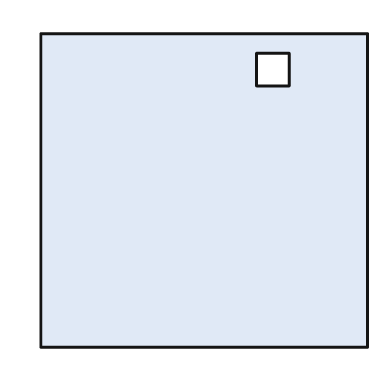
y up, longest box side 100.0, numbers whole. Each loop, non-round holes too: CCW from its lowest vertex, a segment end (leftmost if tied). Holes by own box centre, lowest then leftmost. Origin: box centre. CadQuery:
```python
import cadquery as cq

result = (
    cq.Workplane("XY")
    .moveTo(-50.0, -48.0)
    .lineTo(50.0, -48.0)
    .lineTo(50.0, 48.0)
    .lineTo(-50.0, 48.0)
    .close()
    .moveTo(16.0, 32.0)
    .lineTo(26.0, 32.0)
    .lineTo(26.0, 42.0)
    .lineTo(16.0, 42.0)
    .close()
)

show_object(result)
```